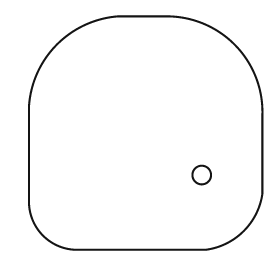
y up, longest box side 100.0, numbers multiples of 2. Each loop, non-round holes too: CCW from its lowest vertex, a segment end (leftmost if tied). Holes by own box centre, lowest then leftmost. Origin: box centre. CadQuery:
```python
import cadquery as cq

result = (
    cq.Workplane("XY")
    .moveTo(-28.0, -50.0)
    .lineTo(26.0, -50.0)
    .threePointArc((42.0, -42.0), (50.0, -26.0))
    .lineTo(50.0, 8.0)
    .threePointArc((38.0, 38.0), (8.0, 50.0))
    .lineTo(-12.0, 50.0)
    .threePointArc((-38.0, 38.0), (-50.0, 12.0))
    .lineTo(-50.0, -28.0)
    .threePointArc((-44.0, -44.0), (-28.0, -50.0))
    .close()
    .moveTo(24.0, -18.0)
    .circle(4.0)
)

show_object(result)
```